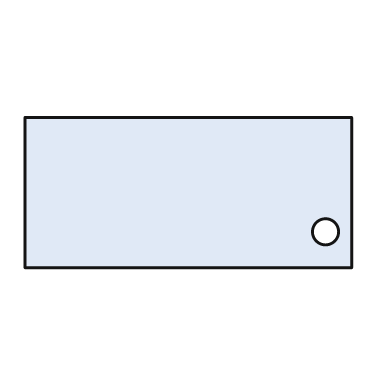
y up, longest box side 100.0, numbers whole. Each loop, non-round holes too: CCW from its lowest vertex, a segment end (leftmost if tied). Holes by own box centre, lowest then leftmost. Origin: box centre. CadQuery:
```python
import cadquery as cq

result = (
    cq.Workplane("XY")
    .moveTo(-50.0, -23.0)
    .lineTo(50.0, -23.0)
    .lineTo(50.0, 23.0)
    .lineTo(-50.0, 23.0)
    .close()
    .moveTo(42.0, -12.0)
    .circle(4.0)
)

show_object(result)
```